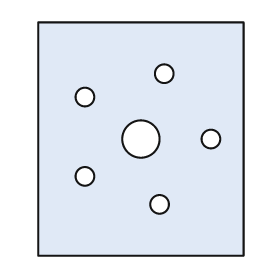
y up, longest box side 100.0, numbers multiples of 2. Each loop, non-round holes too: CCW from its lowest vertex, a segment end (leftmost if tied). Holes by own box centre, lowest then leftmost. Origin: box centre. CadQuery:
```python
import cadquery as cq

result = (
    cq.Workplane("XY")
    .moveTo(-44.0, -50.0)
    .lineTo(44.0, -50.0)
    .lineTo(44.0, 50.0)
    .lineTo(-44.0, 50.0)
    .close()
    .moveTo(8.0, -28.0)
    .circle(4.0)
    .moveTo(-24.0, -16.0)
    .circle(4.0)
    .moveTo(0.0, 0.0)
    .circle(8.0)
    .moveTo(30.0, 0.0)
    .circle(4.0)
    .moveTo(-24.0, 18.0)
    .circle(4.0)
    .moveTo(10.0, 28.0)
    .circle(4.0)
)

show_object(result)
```